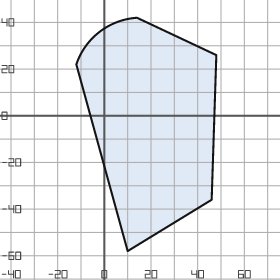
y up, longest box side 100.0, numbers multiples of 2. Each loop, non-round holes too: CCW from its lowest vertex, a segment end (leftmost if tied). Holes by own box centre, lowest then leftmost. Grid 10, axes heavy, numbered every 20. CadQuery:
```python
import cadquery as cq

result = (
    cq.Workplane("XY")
    .moveTo(10.0, -58.0)
    .lineTo(46.0, -36.0)
    .lineTo(48.0, 26.0)
    .lineTo(14.0, 42.0)
    .threePointArc((-2.0, 36.0), (-12.0, 22.0))
    .close()
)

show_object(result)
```